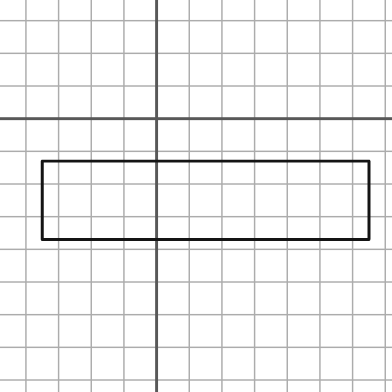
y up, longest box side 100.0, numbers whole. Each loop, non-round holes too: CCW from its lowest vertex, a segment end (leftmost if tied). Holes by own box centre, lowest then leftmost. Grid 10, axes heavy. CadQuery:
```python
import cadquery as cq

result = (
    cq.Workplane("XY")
    .moveTo(-35.0, -37.0)
    .lineTo(65.0, -37.0)
    .lineTo(65.0, -13.0)
    .lineTo(-35.0, -13.0)
    .close()
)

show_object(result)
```